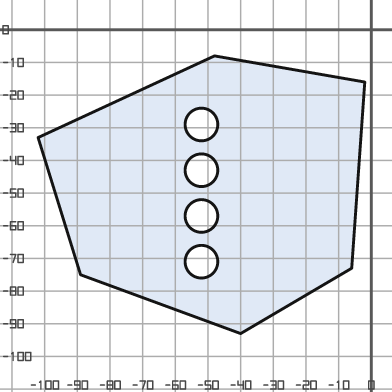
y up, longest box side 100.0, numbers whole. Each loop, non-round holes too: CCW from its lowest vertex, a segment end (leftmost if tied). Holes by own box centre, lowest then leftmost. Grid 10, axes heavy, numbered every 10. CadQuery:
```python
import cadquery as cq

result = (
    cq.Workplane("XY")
    .moveTo(-40.0, -93.0)
    .lineTo(-6.0, -73.0)
    .lineTo(-2.0, -16.0)
    .lineTo(-48.0, -8.0)
    .lineTo(-102.0, -33.0)
    .lineTo(-89.0, -75.0)
    .close()
    .moveTo(-52.0, -71.0)
    .circle(5.0)
    .moveTo(-52.0, -57.0)
    .circle(5.0)
    .moveTo(-52.0, -43.0)
    .circle(5.0)
    .moveTo(-52.0, -29.0)
    .circle(5.0)
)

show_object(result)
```